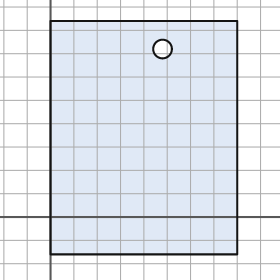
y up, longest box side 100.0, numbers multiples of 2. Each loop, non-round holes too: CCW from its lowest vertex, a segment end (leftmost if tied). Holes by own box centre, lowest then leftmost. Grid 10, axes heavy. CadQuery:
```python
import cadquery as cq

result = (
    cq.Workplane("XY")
    .moveTo(0.0, -16.0)
    .lineTo(80.0, -16.0)
    .lineTo(80.0, 84.0)
    .lineTo(0.0, 84.0)
    .close()
    .moveTo(48.0, 72.0)
    .circle(4.0)
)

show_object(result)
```